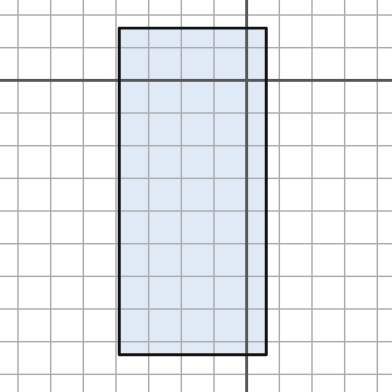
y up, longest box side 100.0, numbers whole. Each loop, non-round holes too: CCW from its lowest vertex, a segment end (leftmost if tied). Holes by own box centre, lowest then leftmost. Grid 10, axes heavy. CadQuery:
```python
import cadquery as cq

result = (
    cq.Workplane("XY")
    .moveTo(-39.0, -84.0)
    .lineTo(6.0, -84.0)
    .lineTo(6.0, 16.0)
    .lineTo(-39.0, 16.0)
    .close()
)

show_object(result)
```